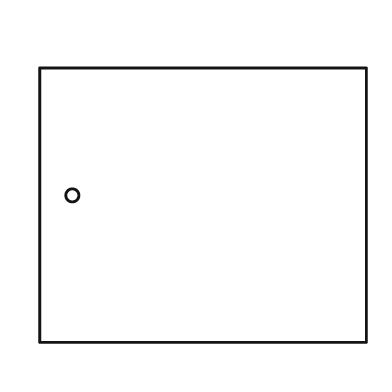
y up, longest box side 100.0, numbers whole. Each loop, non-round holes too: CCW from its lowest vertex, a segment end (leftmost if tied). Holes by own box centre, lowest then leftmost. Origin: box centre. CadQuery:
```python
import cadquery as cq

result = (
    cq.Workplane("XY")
    .moveTo(-50.0, -42.0)
    .lineTo(50.0, -42.0)
    .lineTo(50.0, 42.0)
    .lineTo(-50.0, 42.0)
    .close()
    .moveTo(-40.0, 3.0)
    .circle(2.0)
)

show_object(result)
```